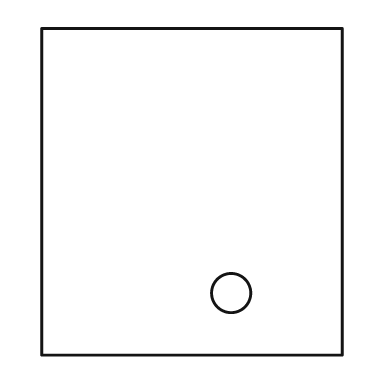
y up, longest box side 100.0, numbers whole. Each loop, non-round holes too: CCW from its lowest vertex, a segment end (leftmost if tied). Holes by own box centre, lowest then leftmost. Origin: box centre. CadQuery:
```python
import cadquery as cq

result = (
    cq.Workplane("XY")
    .moveTo(-46.0, -50.0)
    .lineTo(46.0, -50.0)
    .lineTo(46.0, 50.0)
    .lineTo(-46.0, 50.0)
    .close()
    .moveTo(12.0, -31.0)
    .circle(6.0)
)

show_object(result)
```